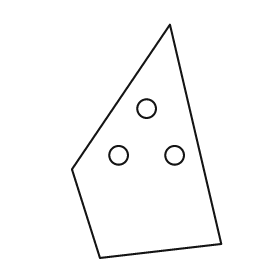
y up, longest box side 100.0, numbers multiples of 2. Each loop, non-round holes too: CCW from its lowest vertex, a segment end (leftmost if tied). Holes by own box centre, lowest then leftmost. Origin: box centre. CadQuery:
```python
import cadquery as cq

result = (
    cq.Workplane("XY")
    .moveTo(-20.0, -50.0)
    .lineTo(32.0, -44.0)
    .lineTo(10.0, 50.0)
    .lineTo(-32.0, -12.0)
    .close()
    .moveTo(-12.0, -6.0)
    .circle(4.0)
    .moveTo(12.0, -6.0)
    .circle(4.0)
    .moveTo(0.0, 14.0)
    .circle(4.0)
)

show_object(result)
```